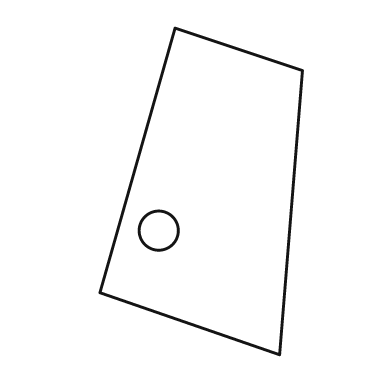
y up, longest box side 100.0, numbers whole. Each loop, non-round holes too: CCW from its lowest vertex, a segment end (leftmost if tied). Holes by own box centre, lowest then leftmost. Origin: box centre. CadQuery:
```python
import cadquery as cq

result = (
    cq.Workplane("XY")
    .moveTo(24.0, -50.0)
    .lineTo(31.0, 37.0)
    .lineTo(-8.0, 50.0)
    .lineTo(-31.0, -31.0)
    .close()
    .moveTo(-13.0, -12.0)
    .circle(6.0)
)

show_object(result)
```